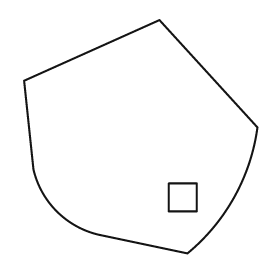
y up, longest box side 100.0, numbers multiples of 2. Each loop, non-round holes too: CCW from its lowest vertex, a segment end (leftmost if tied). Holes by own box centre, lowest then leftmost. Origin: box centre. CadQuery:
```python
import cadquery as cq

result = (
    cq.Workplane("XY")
    .moveTo(20.0, -50.0)
    .threePointArc((40.0, -26.0), (50.0, 4.0))
    .lineTo(8.0, 50.0)
    .lineTo(-50.0, 24.0)
    .lineTo(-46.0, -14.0)
    .threePointArc((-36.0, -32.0), (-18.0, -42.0))
    .close()
    .moveTo(12.0, -32.0)
    .lineTo(24.0, -32.0)
    .lineTo(24.0, -20.0)
    .lineTo(12.0, -20.0)
    .close()
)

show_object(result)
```